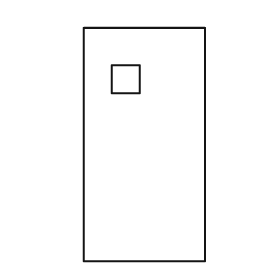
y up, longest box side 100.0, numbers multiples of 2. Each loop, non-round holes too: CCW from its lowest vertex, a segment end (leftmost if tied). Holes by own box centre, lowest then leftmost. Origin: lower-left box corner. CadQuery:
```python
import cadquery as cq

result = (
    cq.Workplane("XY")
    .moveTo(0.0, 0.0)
    .lineTo(52.0, 0.0)
    .lineTo(52.0, 100.0)
    .lineTo(0.0, 100.0)
    .close()
    .moveTo(12.0, 72.0)
    .lineTo(24.0, 72.0)
    .lineTo(24.0, 84.0)
    .lineTo(12.0, 84.0)
    .close()
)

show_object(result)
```